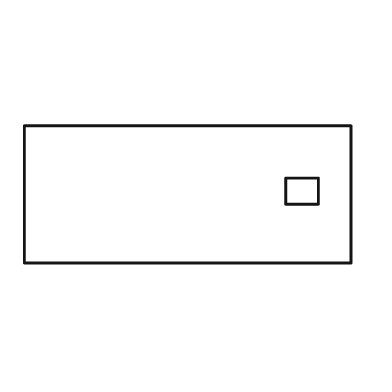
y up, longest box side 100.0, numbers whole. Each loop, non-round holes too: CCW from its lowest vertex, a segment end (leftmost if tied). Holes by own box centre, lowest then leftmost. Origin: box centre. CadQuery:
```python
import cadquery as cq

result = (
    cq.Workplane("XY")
    .moveTo(-50.0, -21.0)
    .lineTo(50.0, -21.0)
    .lineTo(50.0, 21.0)
    .lineTo(-50.0, 21.0)
    .close()
    .moveTo(30.0, -3.0)
    .lineTo(40.0, -3.0)
    .lineTo(40.0, 5.0)
    .lineTo(30.0, 5.0)
    .close()
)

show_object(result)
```